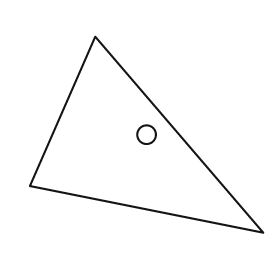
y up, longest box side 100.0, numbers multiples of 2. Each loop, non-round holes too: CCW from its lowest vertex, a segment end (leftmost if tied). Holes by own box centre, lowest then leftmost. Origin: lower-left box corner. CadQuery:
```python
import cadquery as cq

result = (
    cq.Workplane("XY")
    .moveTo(100.0, 0.0)
    .lineTo(28.0, 84.0)
    .lineTo(0.0, 20.0)
    .close()
    .moveTo(50.0, 42.0)
    .circle(4.0)
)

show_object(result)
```